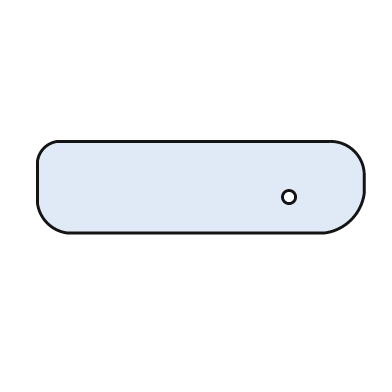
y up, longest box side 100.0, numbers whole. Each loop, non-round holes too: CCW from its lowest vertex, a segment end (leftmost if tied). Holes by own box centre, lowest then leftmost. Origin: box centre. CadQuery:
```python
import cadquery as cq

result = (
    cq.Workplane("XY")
    .moveTo(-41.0, -14.0)
    .lineTo(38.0, -14.0)
    .threePointArc((46.0, -10.0), (50.0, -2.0))
    .lineTo(50.0, 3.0)
    .threePointArc((47.0, 11.0), (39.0, 14.0))
    .lineTo(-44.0, 14.0)
    .threePointArc((-48.0, 12.0), (-50.0, 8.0))
    .lineTo(-50.0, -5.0)
    .threePointArc((-47.0, -11.0), (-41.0, -14.0))
    .close()
    .moveTo(27.0, -3.0)
    .circle(2.0)
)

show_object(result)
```